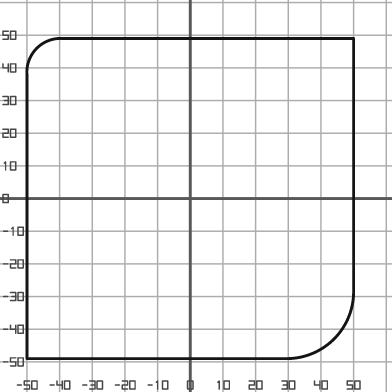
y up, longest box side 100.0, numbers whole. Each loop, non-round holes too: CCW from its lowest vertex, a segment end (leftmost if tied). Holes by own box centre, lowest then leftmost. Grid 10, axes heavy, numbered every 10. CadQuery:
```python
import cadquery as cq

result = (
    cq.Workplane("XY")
    .moveTo(-50.0, -49.0)
    .lineTo(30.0, -49.0)
    .threePointArc((44.0, -43.0), (50.0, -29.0))
    .lineTo(50.0, 49.0)
    .lineTo(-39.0, 49.0)
    .threePointArc((-47.0, 46.0), (-50.0, 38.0))
    .close()
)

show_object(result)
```